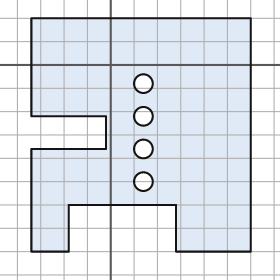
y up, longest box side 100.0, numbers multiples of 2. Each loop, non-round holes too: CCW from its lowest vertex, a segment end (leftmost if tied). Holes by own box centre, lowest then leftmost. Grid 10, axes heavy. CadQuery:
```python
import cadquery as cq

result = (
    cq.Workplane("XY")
    .moveTo(-34.0, -80.0)
    .lineTo(-18.0, -80.0)
    .lineTo(-18.0, -60.0)
    .lineTo(28.0, -60.0)
    .lineTo(28.0, -80.0)
    .lineTo(60.0, -80.0)
    .lineTo(60.0, 20.0)
    .lineTo(-34.0, 20.0)
    .lineTo(-34.0, -22.0)
    .lineTo(-2.0, -22.0)
    .lineTo(-2.0, -36.0)
    .lineTo(-34.0, -36.0)
    .close()
    .moveTo(14.0, -50.0)
    .circle(4.0)
    .moveTo(14.0, -36.0)
    .circle(4.0)
    .moveTo(14.0, -22.0)
    .circle(4.0)
    .moveTo(14.0, -8.0)
    .circle(4.0)
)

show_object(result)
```